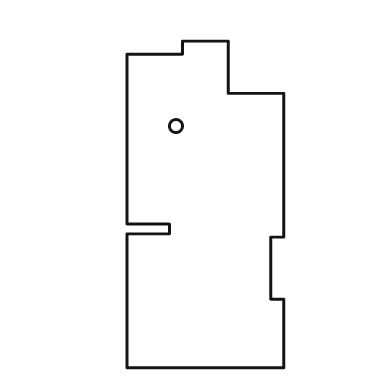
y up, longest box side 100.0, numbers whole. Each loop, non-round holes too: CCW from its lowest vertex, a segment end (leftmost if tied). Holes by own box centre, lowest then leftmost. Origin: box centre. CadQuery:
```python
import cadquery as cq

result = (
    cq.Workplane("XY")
    .moveTo(-24.0, -50.0)
    .lineTo(24.0, -50.0)
    .lineTo(24.0, -29.0)
    .lineTo(20.0, -29.0)
    .lineTo(20.0, -10.0)
    .lineTo(24.0, -10.0)
    .lineTo(24.0, 34.0)
    .lineTo(7.0, 34.0)
    .lineTo(7.0, 50.0)
    .lineTo(-7.0, 50.0)
    .lineTo(-7.0, 46.0)
    .lineTo(-24.0, 46.0)
    .lineTo(-24.0, -6.0)
    .lineTo(-11.0, -6.0)
    .lineTo(-11.0, -9.0)
    .lineTo(-24.0, -9.0)
    .close()
    .moveTo(-9.0, 24.0)
    .circle(2.0)
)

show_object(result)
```